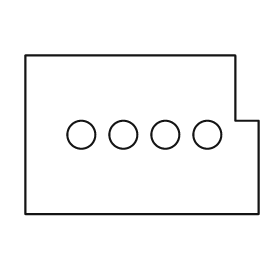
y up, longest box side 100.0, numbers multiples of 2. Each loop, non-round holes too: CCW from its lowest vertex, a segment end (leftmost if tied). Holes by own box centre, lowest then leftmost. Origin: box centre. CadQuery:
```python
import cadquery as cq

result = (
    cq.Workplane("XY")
    .moveTo(-50.0, -34.0)
    .lineTo(50.0, -34.0)
    .lineTo(50.0, 6.0)
    .lineTo(40.0, 6.0)
    .lineTo(40.0, 34.0)
    .lineTo(-50.0, 34.0)
    .close()
    .moveTo(-26.0, 0.0)
    .circle(6.0)
    .moveTo(-8.0, 0.0)
    .circle(6.0)
    .moveTo(10.0, 0.0)
    .circle(6.0)
    .moveTo(28.0, 0.0)
    .circle(6.0)
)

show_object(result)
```